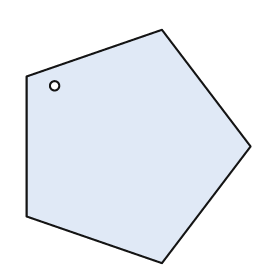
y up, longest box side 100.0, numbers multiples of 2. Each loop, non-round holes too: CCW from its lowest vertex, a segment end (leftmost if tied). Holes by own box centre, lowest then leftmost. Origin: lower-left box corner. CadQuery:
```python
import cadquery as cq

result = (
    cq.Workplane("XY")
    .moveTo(58.0, 0.0)
    .lineTo(96.0, 50.0)
    .lineTo(58.0, 100.0)
    .lineTo(0.0, 80.0)
    .lineTo(0.0, 20.0)
    .close()
    .moveTo(12.0, 76.0)
    .circle(2.0)
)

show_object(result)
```